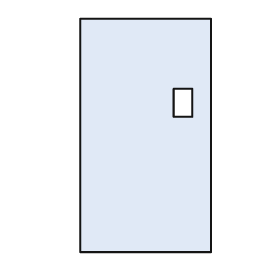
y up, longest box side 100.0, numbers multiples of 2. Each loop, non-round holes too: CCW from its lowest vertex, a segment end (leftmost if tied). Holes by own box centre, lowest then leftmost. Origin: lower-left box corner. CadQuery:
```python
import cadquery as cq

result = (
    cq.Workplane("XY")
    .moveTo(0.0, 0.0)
    .lineTo(56.0, 0.0)
    .lineTo(56.0, 100.0)
    .lineTo(0.0, 100.0)
    .close()
    .moveTo(40.0, 58.0)
    .lineTo(48.0, 58.0)
    .lineTo(48.0, 70.0)
    .lineTo(40.0, 70.0)
    .close()
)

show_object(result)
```